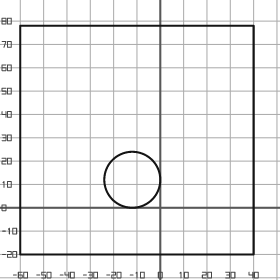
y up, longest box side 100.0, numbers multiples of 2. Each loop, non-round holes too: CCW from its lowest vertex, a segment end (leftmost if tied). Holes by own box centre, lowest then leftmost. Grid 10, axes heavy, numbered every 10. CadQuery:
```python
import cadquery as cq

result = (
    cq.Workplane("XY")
    .moveTo(-60.0, -20.0)
    .lineTo(40.0, -20.0)
    .lineTo(40.0, 78.0)
    .lineTo(-60.0, 78.0)
    .close()
    .moveTo(-12.0, 12.0)
    .circle(12.0)
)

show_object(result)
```